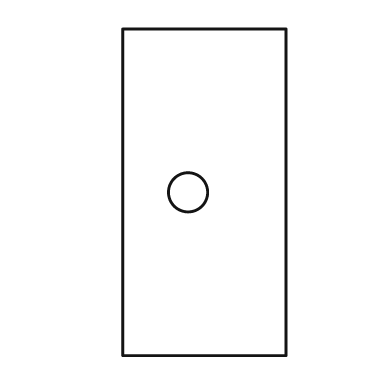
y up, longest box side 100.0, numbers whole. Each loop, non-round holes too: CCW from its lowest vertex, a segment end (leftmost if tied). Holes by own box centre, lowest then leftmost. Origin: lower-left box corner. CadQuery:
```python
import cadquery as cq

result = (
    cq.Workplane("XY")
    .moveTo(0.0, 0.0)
    .lineTo(50.0, 0.0)
    .lineTo(50.0, 100.0)
    .lineTo(0.0, 100.0)
    .close()
    .moveTo(20.0, 50.0)
    .circle(6.0)
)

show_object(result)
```